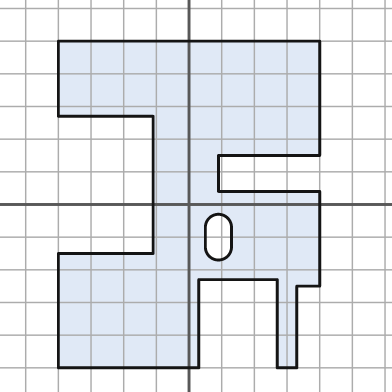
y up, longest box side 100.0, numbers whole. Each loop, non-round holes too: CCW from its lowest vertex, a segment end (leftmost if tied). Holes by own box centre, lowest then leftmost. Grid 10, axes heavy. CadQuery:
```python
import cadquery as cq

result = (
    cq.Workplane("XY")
    .moveTo(-40.0, -50.0)
    .lineTo(3.0, -50.0)
    .lineTo(3.0, -23.0)
    .lineTo(27.0, -23.0)
    .lineTo(27.0, -50.0)
    .lineTo(33.0, -50.0)
    .lineTo(33.0, -25.0)
    .lineTo(40.0, -25.0)
    .lineTo(40.0, 4.0)
    .lineTo(9.0, 4.0)
    .lineTo(9.0, 15.0)
    .lineTo(40.0, 15.0)
    .lineTo(40.0, 50.0)
    .lineTo(-40.0, 50.0)
    .lineTo(-40.0, 27.0)
    .lineTo(-11.0, 27.0)
    .lineTo(-11.0, -15.0)
    .lineTo(-40.0, -15.0)
    .close()
    .moveTo(5.0, -13.0)
    .threePointArc((9.0, -17.0), (13.0, -13.0))
    .lineTo(13.0, -7.0)
    .threePointArc((9.0, -3.0), (5.0, -7.0))
    .close()
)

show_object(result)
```